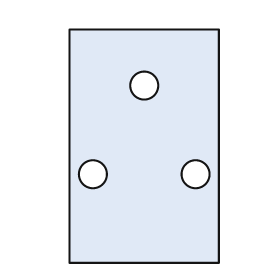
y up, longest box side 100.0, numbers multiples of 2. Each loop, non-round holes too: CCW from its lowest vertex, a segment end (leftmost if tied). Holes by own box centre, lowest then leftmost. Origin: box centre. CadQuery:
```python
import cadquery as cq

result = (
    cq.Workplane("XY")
    .moveTo(-32.0, -50.0)
    .lineTo(32.0, -50.0)
    .lineTo(32.0, 50.0)
    .lineTo(-32.0, 50.0)
    .close()
    .moveTo(-22.0, -12.0)
    .circle(6.0)
    .moveTo(22.0, -12.0)
    .circle(6.0)
    .moveTo(0.0, 26.0)
    .circle(6.0)
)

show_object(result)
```